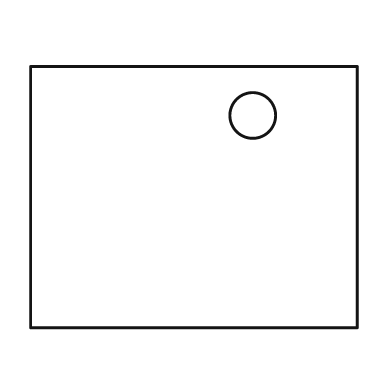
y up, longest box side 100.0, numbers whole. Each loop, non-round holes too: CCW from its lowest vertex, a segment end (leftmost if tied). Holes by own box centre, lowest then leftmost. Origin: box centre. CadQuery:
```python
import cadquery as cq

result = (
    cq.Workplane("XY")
    .moveTo(-50.0, -40.0)
    .lineTo(50.0, -40.0)
    .lineTo(50.0, 40.0)
    .lineTo(-50.0, 40.0)
    .close()
    .moveTo(18.0, 25.0)
    .circle(7.0)
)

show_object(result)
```